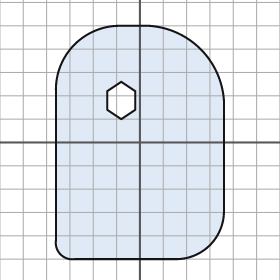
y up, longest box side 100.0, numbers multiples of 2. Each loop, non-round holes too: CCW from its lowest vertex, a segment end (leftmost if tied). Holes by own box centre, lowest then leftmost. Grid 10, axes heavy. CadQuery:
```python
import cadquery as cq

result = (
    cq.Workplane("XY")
    .moveTo(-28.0, -50.0)
    .lineTo(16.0, -50.0)
    .threePointArc((30.0, -44.0), (36.0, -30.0))
    .lineTo(36.0, 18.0)
    .threePointArc((26.0, 40.0), (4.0, 50.0))
    .lineTo(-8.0, 50.0)
    .threePointArc((-28.0, 42.0), (-36.0, 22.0))
    .lineTo(-36.0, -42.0)
    .threePointArc((-34.0, -48.0), (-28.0, -50.0))
    .close()
    .moveTo(-8.0, 10.0)
    .lineTo(-2.0, 14.0)
    .lineTo(-2.0, 22.0)
    .lineTo(-8.0, 26.0)
    .lineTo(-14.0, 22.0)
    .lineTo(-14.0, 14.0)
    .close()
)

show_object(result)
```